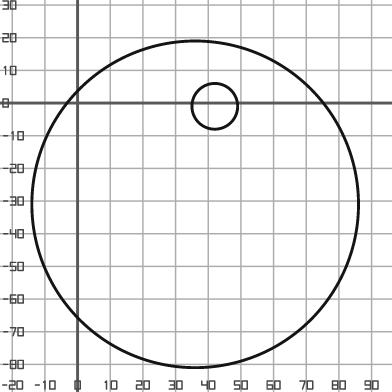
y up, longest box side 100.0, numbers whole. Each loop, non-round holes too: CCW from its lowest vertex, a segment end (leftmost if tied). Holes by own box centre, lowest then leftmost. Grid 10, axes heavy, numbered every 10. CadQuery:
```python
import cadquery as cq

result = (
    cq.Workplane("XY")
    .moveTo(36.0, -31.0)
    .circle(50.0)
    .moveTo(42.0, -1.0)
    .circle(7.0)
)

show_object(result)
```